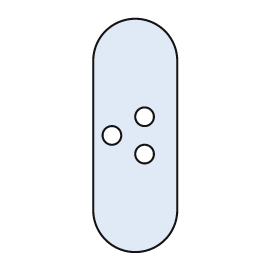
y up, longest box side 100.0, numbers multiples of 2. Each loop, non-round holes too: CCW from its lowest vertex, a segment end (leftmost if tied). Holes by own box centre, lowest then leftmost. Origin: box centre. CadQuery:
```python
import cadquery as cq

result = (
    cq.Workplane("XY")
    .moveTo(-18.0, -32.0)
    .threePointArc((0.0, -50.0), (18.0, -32.0))
    .lineTo(18.0, 32.0)
    .threePointArc((0.0, 50.0), (-18.0, 32.0))
    .close()
    .moveTo(4.0, -8.0)
    .circle(4.0)
    .moveTo(-10.0, 0.0)
    .circle(4.0)
    .moveTo(4.0, 8.0)
    .circle(4.0)
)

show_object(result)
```